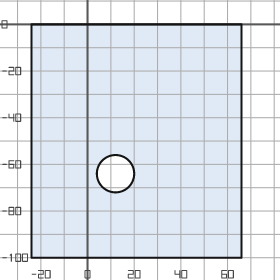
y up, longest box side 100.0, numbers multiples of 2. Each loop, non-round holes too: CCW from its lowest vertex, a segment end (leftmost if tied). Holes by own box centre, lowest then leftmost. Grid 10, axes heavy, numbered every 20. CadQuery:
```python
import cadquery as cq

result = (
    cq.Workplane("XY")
    .moveTo(-24.0, -100.0)
    .lineTo(66.0, -100.0)
    .lineTo(66.0, 0.0)
    .lineTo(-24.0, 0.0)
    .close()
    .moveTo(12.0, -64.0)
    .circle(8.0)
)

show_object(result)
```